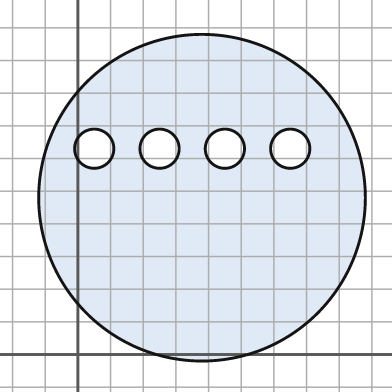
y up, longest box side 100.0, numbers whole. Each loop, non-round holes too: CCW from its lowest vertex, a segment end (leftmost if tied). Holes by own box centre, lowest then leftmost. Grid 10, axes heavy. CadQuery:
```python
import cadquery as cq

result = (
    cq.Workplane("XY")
    .moveTo(38.0, 48.0)
    .circle(50.0)
    .moveTo(5.0, 63.0)
    .circle(6.0)
    .moveTo(25.0, 63.0)
    .circle(6.0)
    .moveTo(45.0, 63.0)
    .circle(6.0)
    .moveTo(65.0, 63.0)
    .circle(6.0)
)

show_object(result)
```